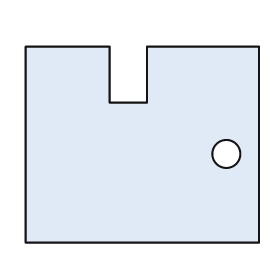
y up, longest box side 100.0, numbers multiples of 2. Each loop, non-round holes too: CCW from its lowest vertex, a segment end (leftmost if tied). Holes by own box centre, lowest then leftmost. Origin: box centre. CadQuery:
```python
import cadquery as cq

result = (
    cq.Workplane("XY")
    .moveTo(-50.0, -42.0)
    .lineTo(50.0, -42.0)
    .lineTo(50.0, 42.0)
    .lineTo(2.0, 42.0)
    .lineTo(2.0, 18.0)
    .lineTo(-14.0, 18.0)
    .lineTo(-14.0, 42.0)
    .lineTo(-50.0, 42.0)
    .close()
    .moveTo(36.0, -4.0)
    .circle(6.0)
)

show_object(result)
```